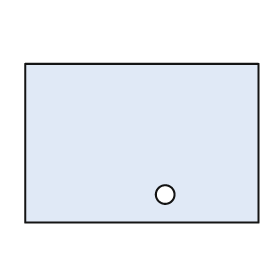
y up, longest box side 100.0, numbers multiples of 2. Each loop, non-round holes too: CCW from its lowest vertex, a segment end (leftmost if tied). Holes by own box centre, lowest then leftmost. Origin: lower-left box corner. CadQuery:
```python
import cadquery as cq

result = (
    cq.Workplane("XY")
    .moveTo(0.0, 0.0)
    .lineTo(100.0, 0.0)
    .lineTo(100.0, 68.0)
    .lineTo(0.0, 68.0)
    .close()
    .moveTo(60.0, 12.0)
    .circle(4.0)
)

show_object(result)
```